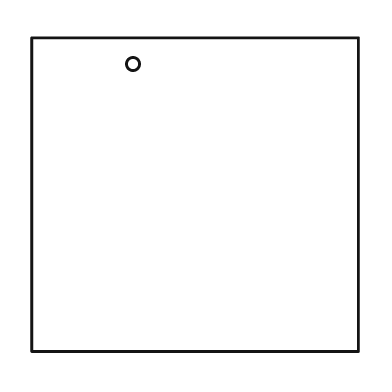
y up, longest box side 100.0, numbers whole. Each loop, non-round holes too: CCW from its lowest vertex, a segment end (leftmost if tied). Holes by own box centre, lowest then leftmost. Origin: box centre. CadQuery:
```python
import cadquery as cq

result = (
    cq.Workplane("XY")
    .moveTo(-50.0, -48.0)
    .lineTo(50.0, -48.0)
    .lineTo(50.0, 48.0)
    .lineTo(-50.0, 48.0)
    .close()
    .moveTo(-19.0, 40.0)
    .circle(2.0)
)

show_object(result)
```